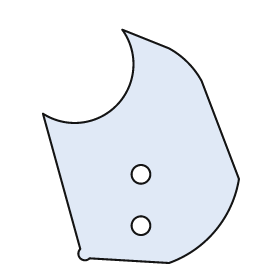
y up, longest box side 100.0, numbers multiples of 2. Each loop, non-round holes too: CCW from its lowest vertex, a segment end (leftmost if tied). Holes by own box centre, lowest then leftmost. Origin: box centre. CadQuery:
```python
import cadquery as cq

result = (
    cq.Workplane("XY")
    .moveTo(12.0, -50.0)
    .threePointArc((32.0, -36.0), (42.0, -14.0))
    .lineTo(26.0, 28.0)
    .threePointArc((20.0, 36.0), (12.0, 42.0))
    .lineTo(-8.0, 50.0)
    .threePointArc((-10.0, 18.0), (-42.0, 14.0))
    .lineTo(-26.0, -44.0)
    .threePointArc((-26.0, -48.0), (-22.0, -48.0))
    .close()
    .moveTo(0.0, -34.0)
    .circle(4.0)
    .moveTo(0.0, -12.0)
    .circle(4.0)
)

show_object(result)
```